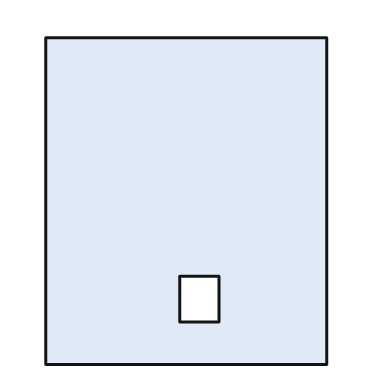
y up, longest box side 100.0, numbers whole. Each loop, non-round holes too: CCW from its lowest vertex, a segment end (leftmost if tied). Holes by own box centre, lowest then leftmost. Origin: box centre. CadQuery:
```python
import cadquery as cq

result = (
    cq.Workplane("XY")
    .moveTo(-43.0, -50.0)
    .lineTo(43.0, -50.0)
    .lineTo(43.0, 50.0)
    .lineTo(-43.0, 50.0)
    .close()
    .moveTo(-2.0, -37.0)
    .lineTo(10.0, -37.0)
    .lineTo(10.0, -23.0)
    .lineTo(-2.0, -23.0)
    .close()
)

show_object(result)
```